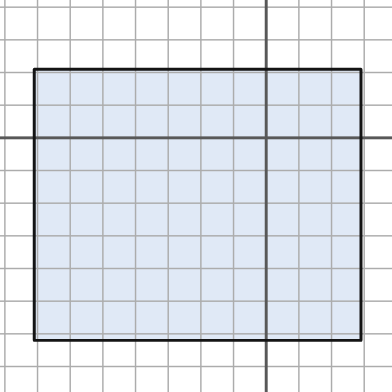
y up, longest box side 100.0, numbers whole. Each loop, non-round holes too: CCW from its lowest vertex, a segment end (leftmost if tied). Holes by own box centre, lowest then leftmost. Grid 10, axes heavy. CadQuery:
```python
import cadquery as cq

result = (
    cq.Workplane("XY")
    .moveTo(-71.0, -62.0)
    .lineTo(29.0, -62.0)
    .lineTo(29.0, 21.0)
    .lineTo(-71.0, 21.0)
    .close()
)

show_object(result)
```